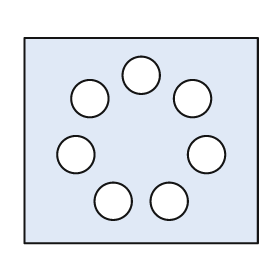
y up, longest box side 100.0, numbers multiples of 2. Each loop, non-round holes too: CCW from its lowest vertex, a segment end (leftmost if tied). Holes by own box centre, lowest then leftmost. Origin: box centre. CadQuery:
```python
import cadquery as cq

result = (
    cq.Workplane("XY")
    .moveTo(-50.0, -44.0)
    .lineTo(50.0, -44.0)
    .lineTo(50.0, 44.0)
    .lineTo(-50.0, 44.0)
    .close()
    .moveTo(-12.0, -26.0)
    .circle(8.0)
    .moveTo(12.0, -26.0)
    .circle(8.0)
    .moveTo(-28.0, -6.0)
    .circle(8.0)
    .moveTo(28.0, -6.0)
    .circle(8.0)
    .moveTo(-22.0, 18.0)
    .circle(8.0)
    .moveTo(22.0, 18.0)
    .circle(8.0)
    .moveTo(0.0, 28.0)
    .circle(8.0)
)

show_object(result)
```